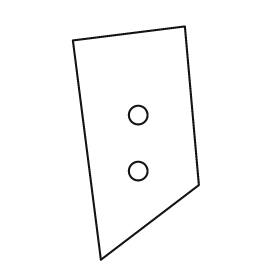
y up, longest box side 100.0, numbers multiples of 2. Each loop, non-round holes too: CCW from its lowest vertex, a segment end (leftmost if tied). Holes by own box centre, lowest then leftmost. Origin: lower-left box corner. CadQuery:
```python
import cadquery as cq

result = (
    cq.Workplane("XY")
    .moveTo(12.0, 0.0)
    .lineTo(54.0, 32.0)
    .lineTo(48.0, 100.0)
    .lineTo(0.0, 94.0)
    .close()
    .moveTo(28.0, 38.0)
    .circle(4.0)
    .moveTo(28.0, 62.0)
    .circle(4.0)
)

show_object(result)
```